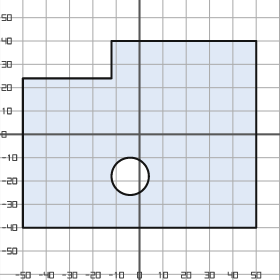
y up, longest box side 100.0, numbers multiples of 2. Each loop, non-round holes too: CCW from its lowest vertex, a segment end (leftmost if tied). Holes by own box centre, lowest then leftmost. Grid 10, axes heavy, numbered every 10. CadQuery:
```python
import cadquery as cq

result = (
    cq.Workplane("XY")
    .moveTo(-50.0, -40.0)
    .lineTo(50.0, -40.0)
    .lineTo(50.0, 40.0)
    .lineTo(-12.0, 40.0)
    .lineTo(-12.0, 24.0)
    .lineTo(-50.0, 24.0)
    .close()
    .moveTo(-4.0, -18.0)
    .circle(8.0)
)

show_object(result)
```